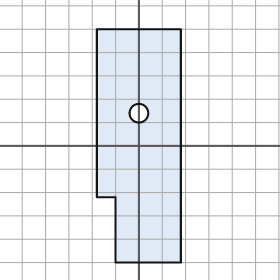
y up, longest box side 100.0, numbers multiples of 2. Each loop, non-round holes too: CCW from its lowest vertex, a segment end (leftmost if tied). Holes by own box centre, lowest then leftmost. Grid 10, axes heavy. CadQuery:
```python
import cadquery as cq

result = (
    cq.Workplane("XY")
    .moveTo(-10.0, -50.0)
    .lineTo(18.0, -50.0)
    .lineTo(18.0, 50.0)
    .lineTo(-18.0, 50.0)
    .lineTo(-18.0, -22.0)
    .lineTo(-10.0, -22.0)
    .close()
    .moveTo(0.0, 14.0)
    .circle(4.0)
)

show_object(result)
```